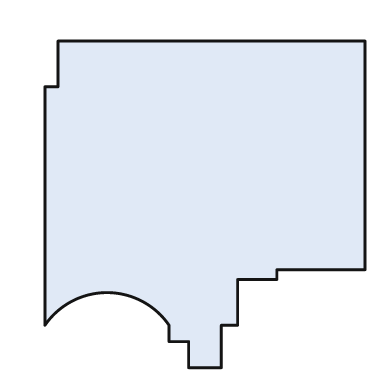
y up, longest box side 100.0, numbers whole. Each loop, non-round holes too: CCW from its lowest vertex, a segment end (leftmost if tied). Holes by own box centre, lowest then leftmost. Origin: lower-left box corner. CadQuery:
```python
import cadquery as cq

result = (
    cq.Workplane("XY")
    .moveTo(44.0, 0.0)
    .lineTo(54.0, 0.0)
    .lineTo(54.0, 13.0)
    .lineTo(59.0, 13.0)
    .lineTo(59.0, 27.0)
    .lineTo(71.0, 27.0)
    .lineTo(71.0, 30.0)
    .lineTo(98.0, 30.0)
    .lineTo(98.0, 100.0)
    .lineTo(4.0, 100.0)
    .lineTo(4.0, 86.0)
    .lineTo(0.0, 86.0)
    .lineTo(0.0, 13.0)
    .threePointArc((19.0, 23.0), (38.0, 13.0))
    .lineTo(38.0, 8.0)
    .lineTo(44.0, 8.0)
    .close()
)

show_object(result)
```